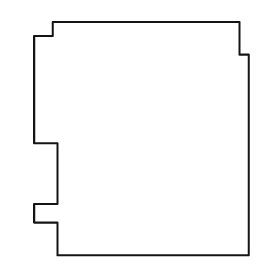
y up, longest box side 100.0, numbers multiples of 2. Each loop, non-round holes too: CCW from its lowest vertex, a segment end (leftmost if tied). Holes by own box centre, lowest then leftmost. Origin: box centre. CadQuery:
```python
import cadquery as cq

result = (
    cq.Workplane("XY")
    .moveTo(-36.0, -50.0)
    .lineTo(46.0, -50.0)
    .lineTo(46.0, 36.0)
    .lineTo(42.0, 36.0)
    .lineTo(42.0, 50.0)
    .lineTo(-38.0, 50.0)
    .lineTo(-38.0, 44.0)
    .lineTo(-46.0, 44.0)
    .lineTo(-46.0, -2.0)
    .lineTo(-36.0, -2.0)
    .lineTo(-36.0, -28.0)
    .lineTo(-46.0, -28.0)
    .lineTo(-46.0, -36.0)
    .lineTo(-36.0, -36.0)
    .close()
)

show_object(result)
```